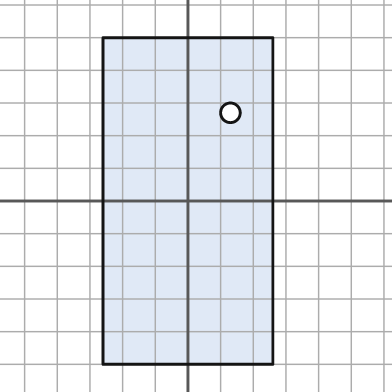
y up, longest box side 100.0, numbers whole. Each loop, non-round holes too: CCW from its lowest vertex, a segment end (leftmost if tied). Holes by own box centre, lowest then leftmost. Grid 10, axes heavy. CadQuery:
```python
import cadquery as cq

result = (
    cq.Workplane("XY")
    .moveTo(-26.0, -50.0)
    .lineTo(26.0, -50.0)
    .lineTo(26.0, 50.0)
    .lineTo(-26.0, 50.0)
    .close()
    .moveTo(13.0, 27.0)
    .circle(3.0)
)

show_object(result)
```